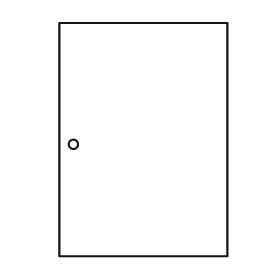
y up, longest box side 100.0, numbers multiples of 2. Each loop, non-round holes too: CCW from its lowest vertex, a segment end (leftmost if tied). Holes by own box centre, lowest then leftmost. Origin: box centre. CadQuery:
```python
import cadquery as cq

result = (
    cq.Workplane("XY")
    .moveTo(-36.0, -50.0)
    .lineTo(36.0, -50.0)
    .lineTo(36.0, 50.0)
    .lineTo(-36.0, 50.0)
    .close()
    .moveTo(-30.0, -2.0)
    .circle(2.0)
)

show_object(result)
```